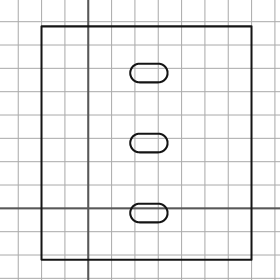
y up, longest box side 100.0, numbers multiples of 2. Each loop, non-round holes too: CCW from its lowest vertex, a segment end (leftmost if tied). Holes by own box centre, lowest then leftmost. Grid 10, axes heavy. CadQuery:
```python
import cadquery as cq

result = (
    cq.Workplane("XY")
    .moveTo(-20.0, -22.0)
    .lineTo(70.0, -22.0)
    .lineTo(70.0, 78.0)
    .lineTo(-20.0, 78.0)
    .close()
    .moveTo(22.0, -6.0)
    .lineTo(30.0, -6.0)
    .threePointArc((34.0, -2.0), (30.0, 2.0))
    .lineTo(22.0, 2.0)
    .threePointArc((18.0, -2.0), (22.0, -6.0))
    .close()
    .moveTo(22.0, 24.0)
    .lineTo(30.0, 24.0)
    .threePointArc((34.0, 28.0), (30.0, 32.0))
    .lineTo(22.0, 32.0)
    .threePointArc((18.0, 28.0), (22.0, 24.0))
    .close()
    .moveTo(22.0, 54.0)
    .lineTo(30.0, 54.0)
    .threePointArc((34.0, 58.0), (30.0, 62.0))
    .lineTo(22.0, 62.0)
    .threePointArc((18.0, 58.0), (22.0, 54.0))
    .close()
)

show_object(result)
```